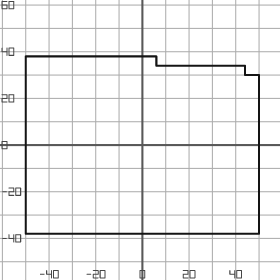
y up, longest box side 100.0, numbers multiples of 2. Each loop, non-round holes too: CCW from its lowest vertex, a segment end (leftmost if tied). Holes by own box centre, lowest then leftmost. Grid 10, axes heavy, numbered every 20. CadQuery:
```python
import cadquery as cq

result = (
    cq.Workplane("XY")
    .moveTo(-50.0, -38.0)
    .lineTo(50.0, -38.0)
    .lineTo(50.0, 30.0)
    .lineTo(44.0, 30.0)
    .lineTo(44.0, 34.0)
    .lineTo(6.0, 34.0)
    .lineTo(6.0, 38.0)
    .lineTo(-50.0, 38.0)
    .close()
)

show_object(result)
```